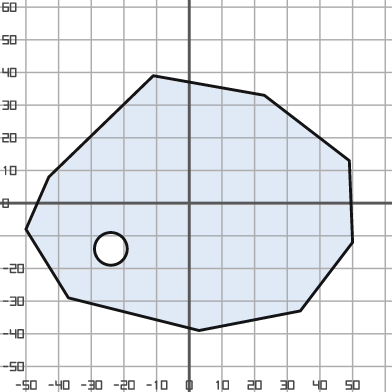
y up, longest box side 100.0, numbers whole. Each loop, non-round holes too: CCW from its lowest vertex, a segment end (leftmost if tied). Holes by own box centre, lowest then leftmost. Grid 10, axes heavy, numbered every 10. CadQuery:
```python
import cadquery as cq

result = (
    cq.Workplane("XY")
    .moveTo(3.0, -39.0)
    .lineTo(34.0, -33.0)
    .lineTo(50.0, -12.0)
    .lineTo(49.0, 13.0)
    .lineTo(23.0, 33.0)
    .lineTo(-11.0, 39.0)
    .lineTo(-43.0, 8.0)
    .lineTo(-50.0, -8.0)
    .lineTo(-37.0, -29.0)
    .close()
    .moveTo(-24.0, -14.0)
    .circle(5.0)
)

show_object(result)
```